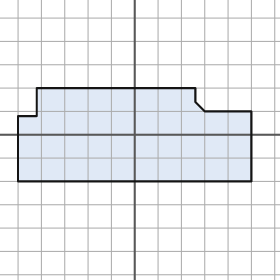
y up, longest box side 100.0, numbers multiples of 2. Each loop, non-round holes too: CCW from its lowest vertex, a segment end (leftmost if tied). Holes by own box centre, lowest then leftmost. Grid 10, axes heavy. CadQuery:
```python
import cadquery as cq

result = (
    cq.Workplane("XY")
    .moveTo(-50.0, -20.0)
    .lineTo(50.0, -20.0)
    .lineTo(50.0, 10.0)
    .lineTo(30.0, 10.0)
    .lineTo(26.0, 14.0)
    .lineTo(26.0, 20.0)
    .lineTo(-42.0, 20.0)
    .lineTo(-42.0, 8.0)
    .lineTo(-50.0, 8.0)
    .close()
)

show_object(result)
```